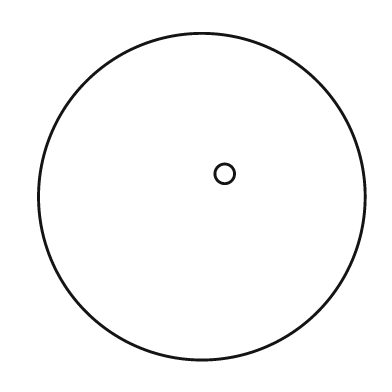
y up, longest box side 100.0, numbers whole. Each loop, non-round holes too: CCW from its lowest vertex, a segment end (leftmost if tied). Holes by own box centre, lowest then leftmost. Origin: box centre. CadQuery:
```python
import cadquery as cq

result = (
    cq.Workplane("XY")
    .moveTo(0.0, 0.0)
    .circle(50.0)
    .moveTo(7.0, 7.0)
    .circle(3.0)
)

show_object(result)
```